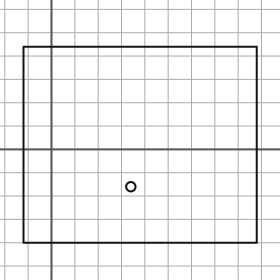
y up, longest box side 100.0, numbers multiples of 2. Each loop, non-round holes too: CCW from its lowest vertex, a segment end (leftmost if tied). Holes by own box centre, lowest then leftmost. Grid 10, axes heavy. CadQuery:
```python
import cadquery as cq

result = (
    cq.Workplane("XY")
    .moveTo(-12.0, -40.0)
    .lineTo(88.0, -40.0)
    .lineTo(88.0, 44.0)
    .lineTo(-12.0, 44.0)
    .close()
    .moveTo(34.0, -16.0)
    .circle(2.0)
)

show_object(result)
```